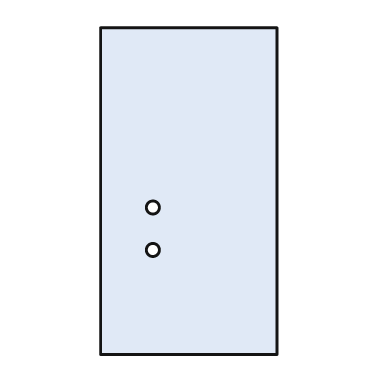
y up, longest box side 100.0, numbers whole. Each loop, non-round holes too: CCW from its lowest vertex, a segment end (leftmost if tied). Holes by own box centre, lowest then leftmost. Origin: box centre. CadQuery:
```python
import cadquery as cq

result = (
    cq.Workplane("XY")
    .moveTo(-27.0, -50.0)
    .lineTo(27.0, -50.0)
    .lineTo(27.0, 50.0)
    .lineTo(-27.0, 50.0)
    .close()
    .moveTo(-11.0, -18.0)
    .circle(2.0)
    .moveTo(-11.0, -5.0)
    .circle(2.0)
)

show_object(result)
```